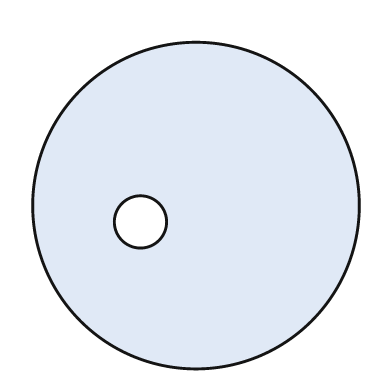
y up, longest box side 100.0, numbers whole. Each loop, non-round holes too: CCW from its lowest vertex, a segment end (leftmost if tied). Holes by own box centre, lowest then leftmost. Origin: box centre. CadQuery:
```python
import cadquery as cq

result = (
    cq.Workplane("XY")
    .moveTo(0.0, 0.0)
    .circle(50.0)
    .moveTo(-17.0, -5.0)
    .circle(8.0)
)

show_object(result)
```